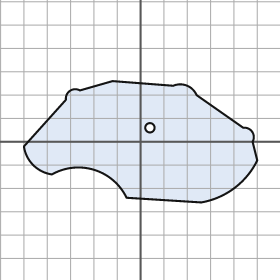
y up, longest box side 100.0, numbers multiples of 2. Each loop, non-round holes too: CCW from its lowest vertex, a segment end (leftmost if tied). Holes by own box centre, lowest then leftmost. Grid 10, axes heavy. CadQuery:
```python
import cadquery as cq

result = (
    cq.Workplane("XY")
    .moveTo(26.0, -26.0)
    .threePointArc((40.0, -20.0), (50.0, -8.0))
    .lineTo(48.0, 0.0)
    .threePointArc((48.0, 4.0), (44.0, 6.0))
    .lineTo(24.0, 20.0)
    .threePointArc((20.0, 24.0), (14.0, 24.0))
    .lineTo(-12.0, 26.0)
    .lineTo(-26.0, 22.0)
    .threePointArc((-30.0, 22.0), (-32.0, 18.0))
    .lineTo(-50.0, -2.0)
    .threePointArc((-46.0, -10.0), (-38.0, -14.0))
    .threePointArc((-20.0, -12.0), (-6.0, -24.0))
    .close()
    .moveTo(4.0, 6.0)
    .circle(2.0)
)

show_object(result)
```